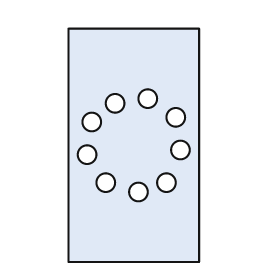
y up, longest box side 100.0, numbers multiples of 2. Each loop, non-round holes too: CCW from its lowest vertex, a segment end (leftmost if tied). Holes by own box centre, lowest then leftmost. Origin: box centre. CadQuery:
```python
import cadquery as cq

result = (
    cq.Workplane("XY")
    .moveTo(-28.0, -50.0)
    .lineTo(28.0, -50.0)
    .lineTo(28.0, 50.0)
    .lineTo(-28.0, 50.0)
    .close()
    .moveTo(2.0, -20.0)
    .circle(4.0)
    .moveTo(-12.0, -16.0)
    .circle(4.0)
    .moveTo(14.0, -16.0)
    .circle(4.0)
    .moveTo(-20.0, -4.0)
    .circle(4.0)
    .moveTo(20.0, -2.0)
    .circle(4.0)
    .moveTo(-18.0, 10.0)
    .circle(4.0)
    .moveTo(18.0, 12.0)
    .circle(4.0)
    .moveTo(-8.0, 18.0)
    .circle(4.0)
    .moveTo(6.0, 20.0)
    .circle(4.0)
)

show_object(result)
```